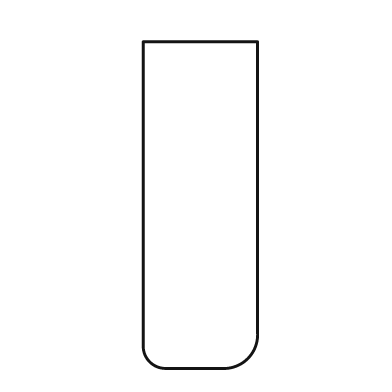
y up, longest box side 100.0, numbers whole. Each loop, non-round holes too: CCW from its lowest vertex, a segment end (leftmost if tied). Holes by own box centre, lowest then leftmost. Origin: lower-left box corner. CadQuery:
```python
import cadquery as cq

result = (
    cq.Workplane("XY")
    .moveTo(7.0, 0.0)
    .lineTo(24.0, 0.0)
    .threePointArc((32.0, 3.0), (35.0, 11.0))
    .lineTo(35.0, 100.0)
    .lineTo(0.0, 100.0)
    .lineTo(0.0, 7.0)
    .threePointArc((2.0, 2.0), (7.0, 0.0))
    .close()
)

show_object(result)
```